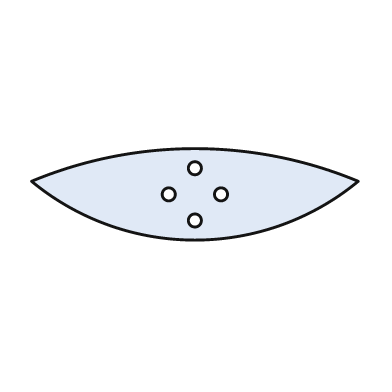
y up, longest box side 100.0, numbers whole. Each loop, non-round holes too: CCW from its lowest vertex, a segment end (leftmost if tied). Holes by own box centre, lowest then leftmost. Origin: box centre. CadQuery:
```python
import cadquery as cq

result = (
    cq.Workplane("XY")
    .moveTo(-50.0, 4.0)
    .threePointArc((0.0, -14.0), (50.0, 4.0))
    .threePointArc((0.0, 14.0), (-50.0, 4.0))
    .close()
    .moveTo(0.0, -8.0)
    .circle(2.0)
    .moveTo(-8.0, 0.0)
    .circle(2.0)
    .moveTo(8.0, 0.0)
    .circle(2.0)
    .moveTo(0.0, 8.0)
    .circle(2.0)
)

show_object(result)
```